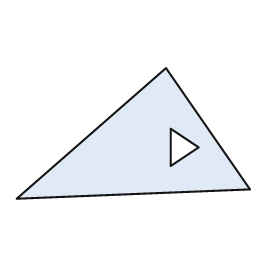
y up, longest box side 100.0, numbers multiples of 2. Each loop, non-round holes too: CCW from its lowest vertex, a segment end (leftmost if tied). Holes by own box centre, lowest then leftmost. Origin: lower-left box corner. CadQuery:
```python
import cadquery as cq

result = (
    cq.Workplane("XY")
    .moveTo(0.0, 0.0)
    .lineTo(100.0, 4.0)
    .lineTo(64.0, 56.0)
    .close()
    .moveTo(66.0, 14.0)
    .lineTo(78.0, 22.0)
    .lineTo(66.0, 30.0)
    .close()
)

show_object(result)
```